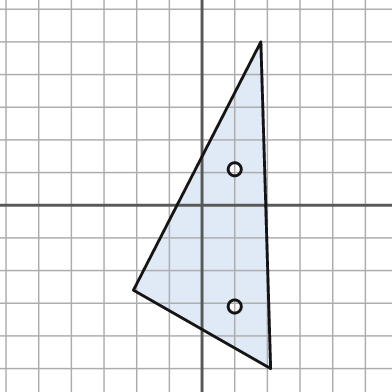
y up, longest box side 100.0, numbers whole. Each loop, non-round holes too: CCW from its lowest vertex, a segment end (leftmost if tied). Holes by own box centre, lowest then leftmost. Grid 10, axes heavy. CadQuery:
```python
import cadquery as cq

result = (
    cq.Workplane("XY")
    .moveTo(21.0, -50.0)
    .lineTo(18.0, 50.0)
    .lineTo(-21.0, -26.0)
    .close()
    .moveTo(10.0, -31.0)
    .circle(2.0)
    .moveTo(10.0, 11.0)
    .circle(2.0)
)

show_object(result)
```